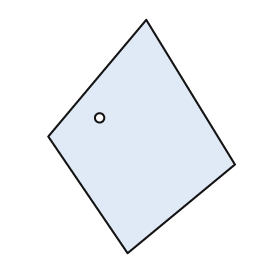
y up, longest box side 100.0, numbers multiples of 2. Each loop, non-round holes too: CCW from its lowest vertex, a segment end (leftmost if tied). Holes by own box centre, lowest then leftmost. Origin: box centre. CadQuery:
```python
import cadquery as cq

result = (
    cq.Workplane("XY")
    .moveTo(-6.0, -50.0)
    .lineTo(40.0, -12.0)
    .lineTo(2.0, 50.0)
    .lineTo(-40.0, 0.0)
    .close()
    .moveTo(-18.0, 8.0)
    .circle(2.0)
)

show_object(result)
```